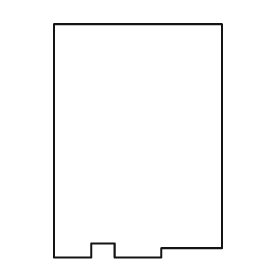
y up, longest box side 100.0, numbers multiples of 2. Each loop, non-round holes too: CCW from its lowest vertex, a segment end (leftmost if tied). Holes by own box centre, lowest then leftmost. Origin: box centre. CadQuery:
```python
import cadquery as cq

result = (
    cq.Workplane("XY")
    .moveTo(-36.0, -50.0)
    .lineTo(-20.0, -50.0)
    .lineTo(-20.0, -44.0)
    .lineTo(-10.0, -44.0)
    .lineTo(-10.0, -50.0)
    .lineTo(10.0, -50.0)
    .lineTo(10.0, -46.0)
    .lineTo(36.0, -46.0)
    .lineTo(36.0, 50.0)
    .lineTo(-36.0, 50.0)
    .close()
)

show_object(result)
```